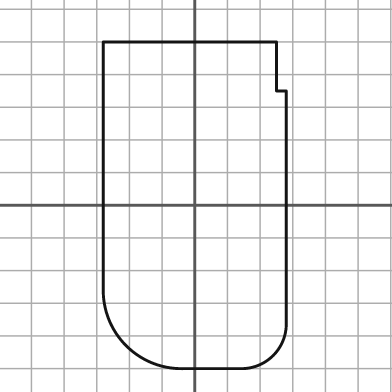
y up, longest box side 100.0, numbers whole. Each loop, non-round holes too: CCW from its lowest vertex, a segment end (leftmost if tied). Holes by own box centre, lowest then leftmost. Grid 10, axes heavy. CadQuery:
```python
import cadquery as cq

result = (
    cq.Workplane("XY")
    .moveTo(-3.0, -50.0)
    .lineTo(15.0, -50.0)
    .threePointArc((24.0, -46.0), (28.0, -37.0))
    .lineTo(28.0, 35.0)
    .lineTo(25.0, 35.0)
    .lineTo(25.0, 50.0)
    .lineTo(-28.0, 50.0)
    .lineTo(-28.0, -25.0)
    .threePointArc((-21.0, -43.0), (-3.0, -50.0))
    .close()
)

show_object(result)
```